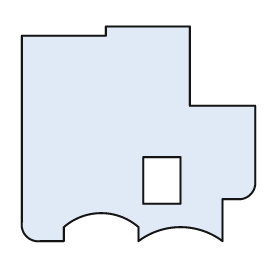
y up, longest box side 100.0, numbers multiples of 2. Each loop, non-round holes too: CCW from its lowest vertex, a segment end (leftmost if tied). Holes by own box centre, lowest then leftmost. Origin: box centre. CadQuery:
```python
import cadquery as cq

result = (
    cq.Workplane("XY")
    .moveTo(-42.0, -46.0)
    .lineTo(-32.0, -46.0)
    .lineTo(-32.0, -40.0)
    .threePointArc((-16.0, -34.0), (0.0, -40.0))
    .lineTo(0.0, -46.0)
    .threePointArc((18.0, -40.0), (36.0, -46.0))
    .lineTo(36.0, -28.0)
    .lineTo(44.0, -28.0)
    .threePointArc((48.0, -26.0), (50.0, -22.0))
    .lineTo(50.0, 12.0)
    .lineTo(22.0, 12.0)
    .lineTo(22.0, 46.0)
    .lineTo(-14.0, 46.0)
    .lineTo(-14.0, 42.0)
    .lineTo(-50.0, 42.0)
    .lineTo(-50.0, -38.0)
    .threePointArc((-48.0, -44.0), (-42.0, -46.0))
    .close()
    .moveTo(2.0, -30.0)
    .lineTo(18.0, -30.0)
    .lineTo(18.0, -10.0)
    .lineTo(2.0, -10.0)
    .close()
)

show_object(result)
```